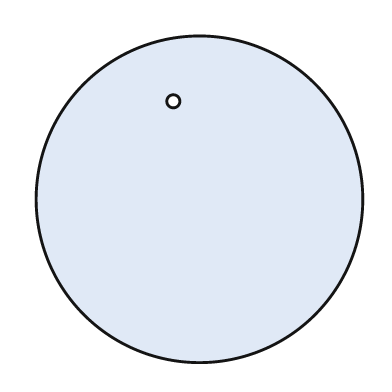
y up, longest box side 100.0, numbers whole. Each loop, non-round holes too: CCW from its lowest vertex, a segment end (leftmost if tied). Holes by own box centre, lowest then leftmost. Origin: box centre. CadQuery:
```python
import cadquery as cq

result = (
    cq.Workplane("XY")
    .moveTo(0.0, 0.0)
    .circle(50.0)
    .moveTo(-8.0, 30.0)
    .circle(2.0)
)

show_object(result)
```